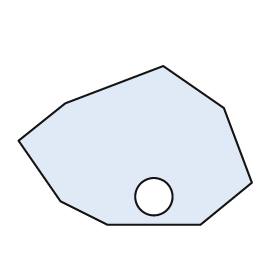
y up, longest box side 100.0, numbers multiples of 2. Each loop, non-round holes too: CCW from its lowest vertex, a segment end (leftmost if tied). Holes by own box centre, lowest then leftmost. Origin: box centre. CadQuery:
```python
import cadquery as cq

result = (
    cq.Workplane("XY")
    .moveTo(-12.0, -34.0)
    .lineTo(28.0, -34.0)
    .lineTo(50.0, -16.0)
    .lineTo(38.0, 16.0)
    .lineTo(12.0, 34.0)
    .lineTo(-30.0, 18.0)
    .lineTo(-50.0, 2.0)
    .lineTo(-32.0, -24.0)
    .close()
    .moveTo(8.0, -22.0)
    .circle(8.0)
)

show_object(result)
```